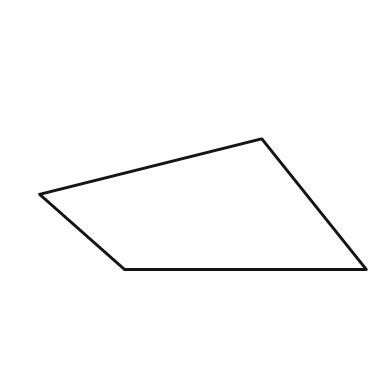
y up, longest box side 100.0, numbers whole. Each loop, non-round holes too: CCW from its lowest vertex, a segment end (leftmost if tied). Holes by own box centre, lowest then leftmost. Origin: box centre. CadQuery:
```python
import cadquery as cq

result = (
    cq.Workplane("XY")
    .moveTo(-24.0, -20.0)
    .lineTo(50.0, -20.0)
    .lineTo(18.0, 20.0)
    .lineTo(-50.0, 3.0)
    .close()
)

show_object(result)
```